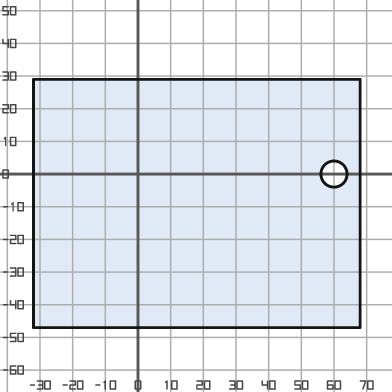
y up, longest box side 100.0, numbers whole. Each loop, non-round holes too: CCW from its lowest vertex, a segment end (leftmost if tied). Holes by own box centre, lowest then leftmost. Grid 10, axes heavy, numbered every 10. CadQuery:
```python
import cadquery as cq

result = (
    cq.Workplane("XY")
    .moveTo(-32.0, -47.0)
    .lineTo(68.0, -47.0)
    .lineTo(68.0, 29.0)
    .lineTo(-32.0, 29.0)
    .close()
    .moveTo(60.0, 0.0)
    .circle(4.0)
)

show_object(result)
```